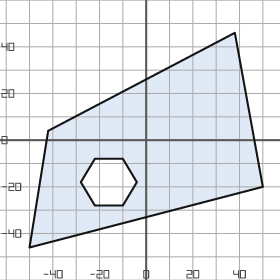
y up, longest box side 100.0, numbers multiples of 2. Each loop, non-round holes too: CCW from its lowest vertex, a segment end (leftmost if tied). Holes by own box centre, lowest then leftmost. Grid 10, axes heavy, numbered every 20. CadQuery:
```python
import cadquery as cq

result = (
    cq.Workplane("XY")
    .moveTo(-50.0, -46.0)
    .lineTo(50.0, -20.0)
    .lineTo(38.0, 46.0)
    .lineTo(-42.0, 4.0)
    .close()
    .moveTo(-22.0, -28.0)
    .lineTo(-10.0, -28.0)
    .lineTo(-4.0, -18.0)
    .lineTo(-10.0, -8.0)
    .lineTo(-22.0, -8.0)
    .lineTo(-28.0, -18.0)
    .close()
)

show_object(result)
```